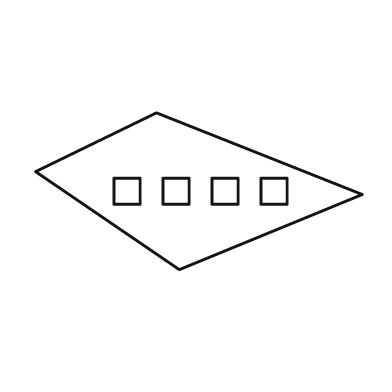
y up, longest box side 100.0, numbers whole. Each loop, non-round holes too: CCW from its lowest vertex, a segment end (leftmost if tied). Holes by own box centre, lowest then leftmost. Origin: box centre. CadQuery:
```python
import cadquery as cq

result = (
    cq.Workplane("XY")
    .moveTo(-6.0, -24.0)
    .lineTo(50.0, -1.0)
    .lineTo(-13.0, 24.0)
    .lineTo(-50.0, 6.0)
    .close()
    .moveTo(-26.0, -4.0)
    .lineTo(-18.0, -4.0)
    .lineTo(-18.0, 4.0)
    .lineTo(-26.0, 4.0)
    .close()
    .moveTo(-11.0, -4.0)
    .lineTo(-3.0, -4.0)
    .lineTo(-3.0, 4.0)
    .lineTo(-11.0, 4.0)
    .close()
    .moveTo(4.0, -4.0)
    .lineTo(12.0, -4.0)
    .lineTo(12.0, 4.0)
    .lineTo(4.0, 4.0)
    .close()
    .moveTo(19.0, -4.0)
    .lineTo(27.0, -4.0)
    .lineTo(27.0, 4.0)
    .lineTo(19.0, 4.0)
    .close()
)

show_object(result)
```